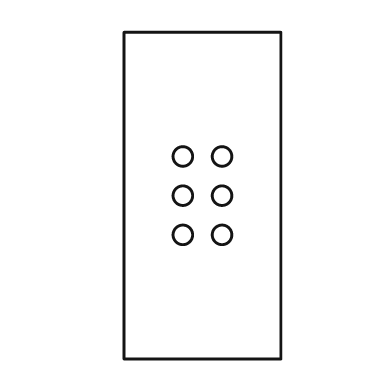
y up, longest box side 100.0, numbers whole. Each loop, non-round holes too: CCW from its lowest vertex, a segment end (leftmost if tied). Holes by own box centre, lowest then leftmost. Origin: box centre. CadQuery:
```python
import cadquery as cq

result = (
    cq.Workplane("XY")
    .moveTo(-24.0, -50.0)
    .lineTo(24.0, -50.0)
    .lineTo(24.0, 50.0)
    .lineTo(-24.0, 50.0)
    .close()
    .moveTo(-6.0, -12.0)
    .circle(3.0)
    .moveTo(6.0, -12.0)
    .circle(3.0)
    .moveTo(-6.0, 0.0)
    .circle(3.0)
    .moveTo(6.0, 0.0)
    .circle(3.0)
    .moveTo(-6.0, 12.0)
    .circle(3.0)
    .moveTo(6.0, 12.0)
    .circle(3.0)
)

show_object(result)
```